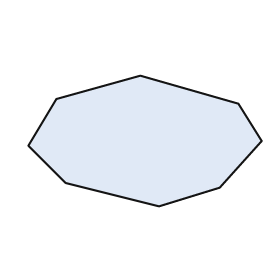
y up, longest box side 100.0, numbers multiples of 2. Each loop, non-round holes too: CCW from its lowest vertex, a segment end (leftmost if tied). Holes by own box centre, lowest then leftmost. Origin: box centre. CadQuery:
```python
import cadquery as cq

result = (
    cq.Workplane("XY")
    .moveTo(6.0, -28.0)
    .lineTo(32.0, -20.0)
    .lineTo(50.0, 0.0)
    .lineTo(40.0, 16.0)
    .lineTo(-2.0, 28.0)
    .lineTo(-38.0, 18.0)
    .lineTo(-50.0, -2.0)
    .lineTo(-34.0, -18.0)
    .close()
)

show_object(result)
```